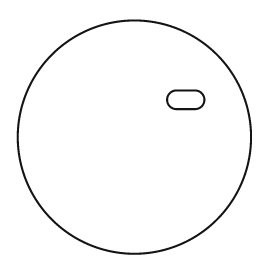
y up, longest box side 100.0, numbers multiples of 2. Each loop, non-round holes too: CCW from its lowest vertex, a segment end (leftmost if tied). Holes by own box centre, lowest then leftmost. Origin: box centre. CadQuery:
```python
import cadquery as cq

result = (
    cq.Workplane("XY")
    .moveTo(0.0, 0.0)
    .circle(50.0)
    .moveTo(18.0, 12.0)
    .lineTo(26.0, 12.0)
    .threePointArc((30.0, 16.0), (26.0, 20.0))
    .lineTo(18.0, 20.0)
    .threePointArc((14.0, 16.0), (18.0, 12.0))
    .close()
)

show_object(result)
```